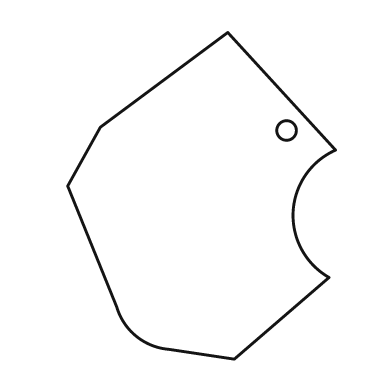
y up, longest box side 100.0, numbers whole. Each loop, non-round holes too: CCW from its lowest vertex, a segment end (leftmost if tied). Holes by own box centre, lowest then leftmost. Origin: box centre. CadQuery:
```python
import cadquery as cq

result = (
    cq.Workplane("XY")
    .moveTo(10.0, -50.0)
    .lineTo(39.0, -25.0)
    .threePointArc((28.0, -5.0), (41.0, 14.0))
    .lineTo(8.0, 50.0)
    .lineTo(-31.0, 21.0)
    .lineTo(-41.0, 3.0)
    .lineTo(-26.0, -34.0)
    .threePointArc((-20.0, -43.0), (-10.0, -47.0))
    .close()
    .moveTo(26.0, 20.0)
    .circle(3.0)
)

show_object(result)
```